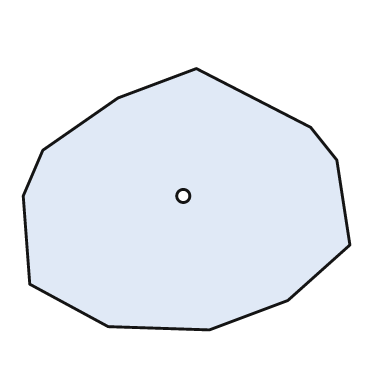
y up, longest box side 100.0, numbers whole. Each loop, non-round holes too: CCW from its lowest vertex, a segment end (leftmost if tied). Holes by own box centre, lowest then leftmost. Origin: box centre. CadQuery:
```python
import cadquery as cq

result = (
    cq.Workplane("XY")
    .moveTo(7.0, -40.0)
    .lineTo(31.0, -31.0)
    .lineTo(50.0, -14.0)
    .lineTo(46.0, 12.0)
    .lineTo(38.0, 22.0)
    .lineTo(3.0, 40.0)
    .lineTo(-21.0, 31.0)
    .lineTo(-44.0, 15.0)
    .lineTo(-50.0, 1.0)
    .lineTo(-48.0, -26.0)
    .lineTo(-24.0, -39.0)
    .close()
    .moveTo(-1.0, 1.0)
    .circle(2.0)
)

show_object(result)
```